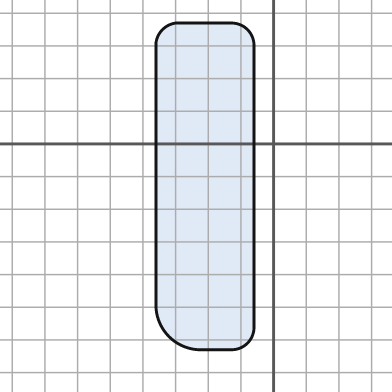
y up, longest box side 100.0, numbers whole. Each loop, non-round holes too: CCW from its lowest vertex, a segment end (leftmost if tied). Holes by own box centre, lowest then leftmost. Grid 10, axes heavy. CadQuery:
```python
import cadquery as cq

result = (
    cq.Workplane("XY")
    .moveTo(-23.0, -63.0)
    .lineTo(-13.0, -63.0)
    .threePointArc((-8.0, -61.0), (-6.0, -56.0))
    .lineTo(-6.0, 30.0)
    .threePointArc((-8.0, 35.0), (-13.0, 37.0))
    .lineTo(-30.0, 37.0)
    .threePointArc((-34.0, 35.0), (-36.0, 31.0))
    .lineTo(-36.0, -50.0)
    .threePointArc((-32.0, -59.0), (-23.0, -63.0))
    .close()
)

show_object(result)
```